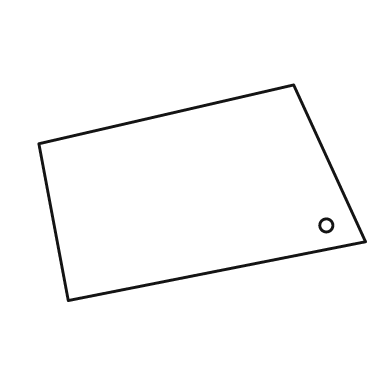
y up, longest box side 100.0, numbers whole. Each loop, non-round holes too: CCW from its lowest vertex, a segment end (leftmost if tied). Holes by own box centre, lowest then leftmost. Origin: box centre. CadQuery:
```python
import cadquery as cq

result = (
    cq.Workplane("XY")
    .moveTo(-41.0, -33.0)
    .lineTo(50.0, -15.0)
    .lineTo(28.0, 33.0)
    .lineTo(-50.0, 15.0)
    .close()
    .moveTo(38.0, -10.0)
    .circle(2.0)
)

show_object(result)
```